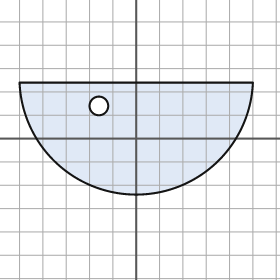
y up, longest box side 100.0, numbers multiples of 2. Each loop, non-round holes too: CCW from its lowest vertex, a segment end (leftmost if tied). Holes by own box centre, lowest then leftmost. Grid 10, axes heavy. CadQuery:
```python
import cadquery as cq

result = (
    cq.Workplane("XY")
    .moveTo(-50.0, 24.0)
    .threePointArc((0.0, -24.0), (50.0, 24.0))
    .close()
    .moveTo(-16.0, 14.0)
    .circle(4.0)
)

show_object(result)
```